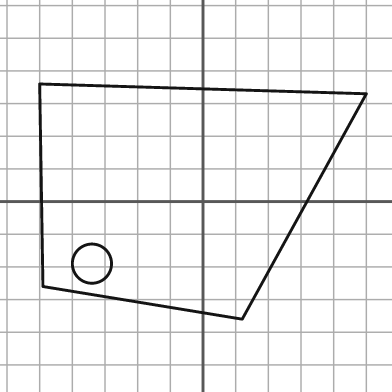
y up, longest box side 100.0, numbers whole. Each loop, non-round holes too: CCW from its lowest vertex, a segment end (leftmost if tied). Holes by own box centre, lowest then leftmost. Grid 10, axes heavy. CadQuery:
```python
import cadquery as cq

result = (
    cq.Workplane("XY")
    .moveTo(12.0, -36.0)
    .lineTo(50.0, 33.0)
    .lineTo(-50.0, 36.0)
    .lineTo(-49.0, -26.0)
    .close()
    .moveTo(-34.0, -19.0)
    .circle(6.0)
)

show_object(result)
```